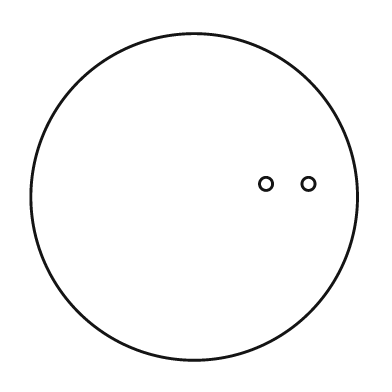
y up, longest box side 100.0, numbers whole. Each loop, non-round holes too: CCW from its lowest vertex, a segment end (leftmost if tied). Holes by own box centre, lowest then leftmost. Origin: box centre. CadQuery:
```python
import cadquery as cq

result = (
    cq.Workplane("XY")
    .moveTo(0.0, 0.0)
    .circle(50.0)
    .moveTo(22.0, 4.0)
    .circle(2.0)
    .moveTo(35.0, 4.0)
    .circle(2.0)
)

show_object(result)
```